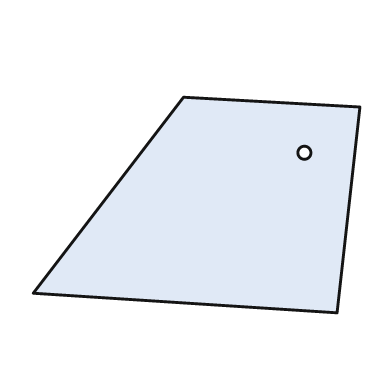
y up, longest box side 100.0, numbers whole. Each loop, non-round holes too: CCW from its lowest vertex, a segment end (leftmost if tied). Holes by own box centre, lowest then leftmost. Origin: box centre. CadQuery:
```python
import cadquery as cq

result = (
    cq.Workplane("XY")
    .moveTo(43.0, -33.0)
    .lineTo(50.0, 30.0)
    .lineTo(-4.0, 33.0)
    .lineTo(-50.0, -27.0)
    .close()
    .moveTo(33.0, 16.0)
    .circle(2.0)
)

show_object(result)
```